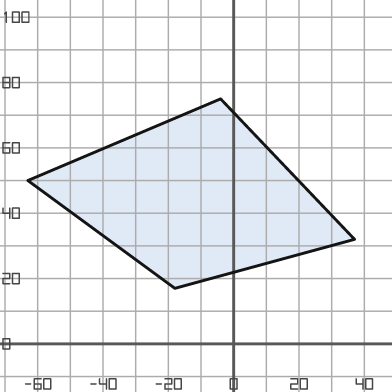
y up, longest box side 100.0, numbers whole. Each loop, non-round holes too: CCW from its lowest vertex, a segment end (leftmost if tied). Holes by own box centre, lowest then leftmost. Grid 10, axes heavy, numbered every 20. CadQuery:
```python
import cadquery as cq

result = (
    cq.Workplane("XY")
    .moveTo(-18.0, 17.0)
    .lineTo(37.0, 32.0)
    .lineTo(-4.0, 75.0)
    .lineTo(-63.0, 50.0)
    .close()
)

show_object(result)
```